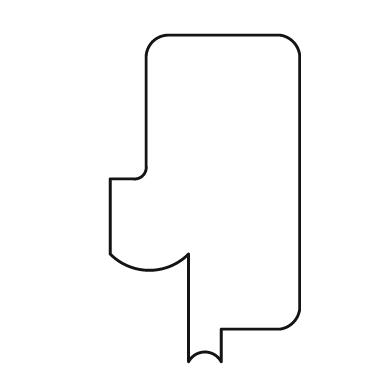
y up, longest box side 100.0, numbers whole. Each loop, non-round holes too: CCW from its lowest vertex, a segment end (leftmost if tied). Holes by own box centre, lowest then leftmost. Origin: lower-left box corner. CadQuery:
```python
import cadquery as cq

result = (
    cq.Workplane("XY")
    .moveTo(24.0, 0.0)
    .threePointArc((29.0, 3.0), (34.0, 0.0))
    .lineTo(34.0, 10.0)
    .lineTo(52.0, 10.0)
    .threePointArc((56.0, 12.0), (58.0, 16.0))
    .lineTo(58.0, 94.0)
    .threePointArc((56.0, 98.0), (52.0, 100.0))
    .lineTo(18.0, 100.0)
    .threePointArc((13.0, 98.0), (11.0, 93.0))
    .lineTo(11.0, 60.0)
    .threePointArc((10.0, 57.0), (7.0, 56.0))
    .lineTo(0.0, 56.0)
    .lineTo(0.0, 33.0)
    .threePointArc((12.0, 28.0), (24.0, 33.0))
    .close()
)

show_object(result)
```